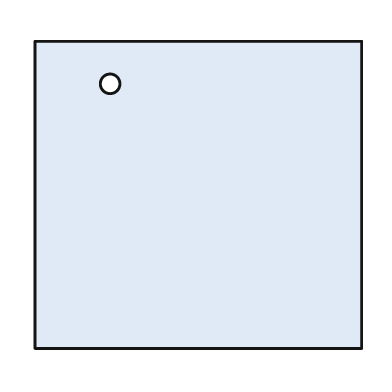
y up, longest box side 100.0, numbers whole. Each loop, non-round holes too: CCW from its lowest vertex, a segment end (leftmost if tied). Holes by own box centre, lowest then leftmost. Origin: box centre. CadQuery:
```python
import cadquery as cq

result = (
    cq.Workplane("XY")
    .moveTo(-50.0, -47.0)
    .lineTo(50.0, -47.0)
    .lineTo(50.0, 47.0)
    .lineTo(-50.0, 47.0)
    .close()
    .moveTo(-27.0, 34.0)
    .circle(3.0)
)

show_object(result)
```